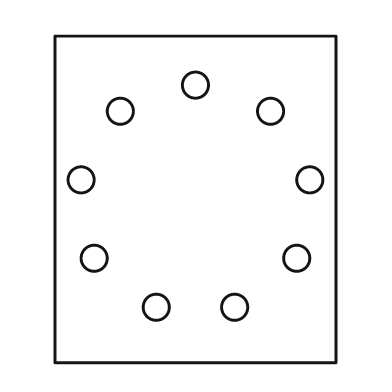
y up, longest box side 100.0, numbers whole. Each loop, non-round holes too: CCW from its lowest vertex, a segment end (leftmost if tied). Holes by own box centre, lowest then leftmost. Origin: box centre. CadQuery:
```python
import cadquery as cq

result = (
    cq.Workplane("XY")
    .moveTo(-43.0, -50.0)
    .lineTo(43.0, -50.0)
    .lineTo(43.0, 50.0)
    .lineTo(-43.0, 50.0)
    .close()
    .moveTo(-12.0, -33.0)
    .circle(4.0)
    .moveTo(12.0, -33.0)
    .circle(4.0)
    .moveTo(-31.0, -18.0)
    .circle(4.0)
    .moveTo(31.0, -18.0)
    .circle(4.0)
    .moveTo(-35.0, 6.0)
    .circle(4.0)
    .moveTo(35.0, 6.0)
    .circle(4.0)
    .moveTo(-23.0, 27.0)
    .circle(4.0)
    .moveTo(23.0, 27.0)
    .circle(4.0)
    .moveTo(0.0, 35.0)
    .circle(4.0)
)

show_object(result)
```